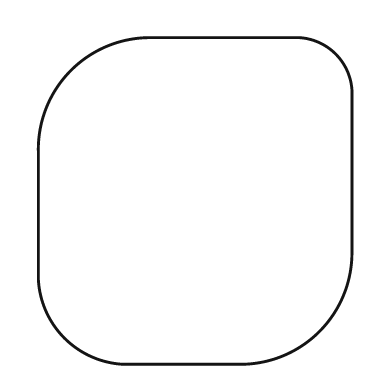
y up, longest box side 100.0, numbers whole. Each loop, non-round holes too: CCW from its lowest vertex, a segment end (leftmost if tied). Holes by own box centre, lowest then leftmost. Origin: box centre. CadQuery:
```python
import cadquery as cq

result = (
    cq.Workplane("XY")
    .moveTo(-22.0, -50.0)
    .lineTo(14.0, -50.0)
    .threePointArc((38.0, -40.0), (48.0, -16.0))
    .lineTo(48.0, 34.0)
    .threePointArc((43.0, 45.0), (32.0, 50.0))
    .lineTo(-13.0, 50.0)
    .threePointArc((-38.0, 40.0), (-48.0, 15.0))
    .lineTo(-48.0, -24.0)
    .threePointArc((-40.0, -42.0), (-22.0, -50.0))
    .close()
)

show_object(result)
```